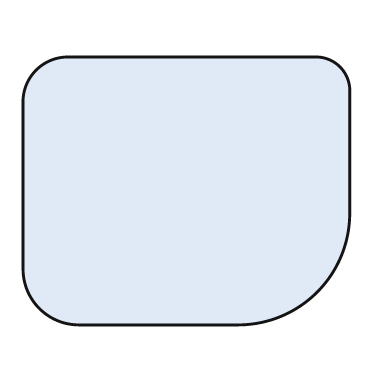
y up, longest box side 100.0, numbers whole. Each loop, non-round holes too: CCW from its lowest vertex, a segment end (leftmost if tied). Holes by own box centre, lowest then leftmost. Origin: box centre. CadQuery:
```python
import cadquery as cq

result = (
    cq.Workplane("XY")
    .moveTo(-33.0, -41.0)
    .lineTo(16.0, -41.0)
    .threePointArc((40.0, -31.0), (50.0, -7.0))
    .lineTo(50.0, 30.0)
    .threePointArc((47.0, 38.0), (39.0, 41.0))
    .lineTo(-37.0, 41.0)
    .threePointArc((-46.0, 37.0), (-50.0, 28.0))
    .lineTo(-50.0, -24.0)
    .threePointArc((-45.0, -36.0), (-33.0, -41.0))
    .close()
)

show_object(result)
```